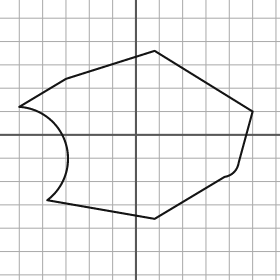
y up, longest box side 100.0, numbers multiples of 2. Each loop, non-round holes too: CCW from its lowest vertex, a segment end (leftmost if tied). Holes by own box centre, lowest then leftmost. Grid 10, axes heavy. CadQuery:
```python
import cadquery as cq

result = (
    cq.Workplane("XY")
    .moveTo(8.0, -36.0)
    .lineTo(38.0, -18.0)
    .threePointArc((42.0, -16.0), (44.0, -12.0))
    .lineTo(50.0, 10.0)
    .lineTo(8.0, 36.0)
    .lineTo(-30.0, 24.0)
    .lineTo(-50.0, 12.0)
    .threePointArc((-30.0, -4.0), (-38.0, -28.0))
    .close()
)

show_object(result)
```